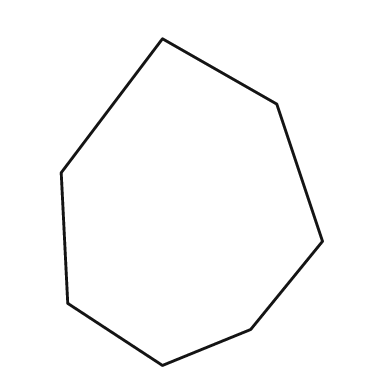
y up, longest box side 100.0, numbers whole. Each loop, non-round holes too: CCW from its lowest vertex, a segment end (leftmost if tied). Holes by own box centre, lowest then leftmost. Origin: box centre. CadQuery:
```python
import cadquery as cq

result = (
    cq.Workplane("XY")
    .moveTo(-9.0, -50.0)
    .lineTo(18.0, -39.0)
    .lineTo(40.0, -12.0)
    .lineTo(26.0, 30.0)
    .lineTo(-9.0, 50.0)
    .lineTo(-40.0, 9.0)
    .lineTo(-38.0, -31.0)
    .close()
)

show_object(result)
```